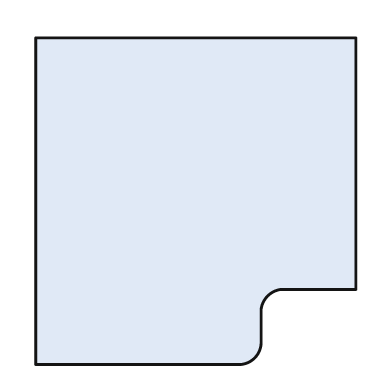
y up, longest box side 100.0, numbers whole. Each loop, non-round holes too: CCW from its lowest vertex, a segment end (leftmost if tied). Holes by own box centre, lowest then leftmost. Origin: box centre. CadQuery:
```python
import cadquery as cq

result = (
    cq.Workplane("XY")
    .moveTo(-49.0, -50.0)
    .lineTo(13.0, -50.0)
    .threePointArc((18.0, -48.0), (20.0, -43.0))
    .lineTo(20.0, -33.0)
    .threePointArc((22.0, -29.0), (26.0, -27.0))
    .lineTo(49.0, -27.0)
    .lineTo(49.0, 50.0)
    .lineTo(-49.0, 50.0)
    .close()
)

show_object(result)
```